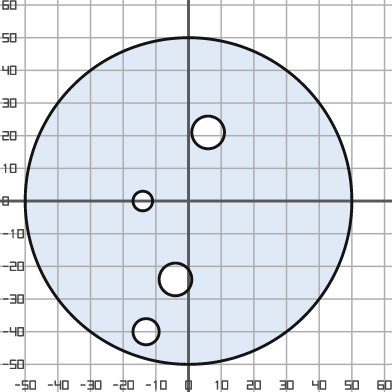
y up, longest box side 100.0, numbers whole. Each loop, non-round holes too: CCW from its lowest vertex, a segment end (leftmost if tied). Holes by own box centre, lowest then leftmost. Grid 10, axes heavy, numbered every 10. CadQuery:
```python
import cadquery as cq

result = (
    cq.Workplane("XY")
    .moveTo(0.0, 0.0)
    .circle(50.0)
    .moveTo(-13.0, -40.0)
    .circle(4.0)
    .moveTo(-4.0, -24.0)
    .circle(5.0)
    .moveTo(-14.0, 0.0)
    .circle(3.0)
    .moveTo(6.0, 21.0)
    .circle(5.0)
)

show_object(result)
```